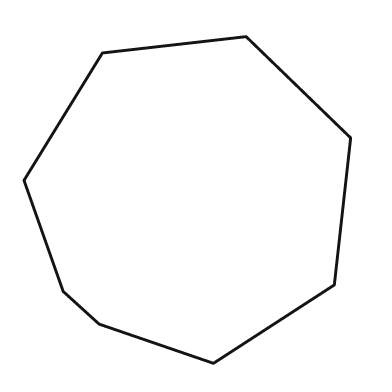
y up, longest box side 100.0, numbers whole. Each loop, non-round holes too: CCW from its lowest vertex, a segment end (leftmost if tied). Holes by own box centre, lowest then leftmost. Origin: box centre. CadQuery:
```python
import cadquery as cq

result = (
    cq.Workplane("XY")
    .moveTo(8.0, -50.0)
    .lineTo(45.0, -26.0)
    .lineTo(50.0, 19.0)
    .lineTo(18.0, 50.0)
    .lineTo(-26.0, 45.0)
    .lineTo(-50.0, 6.0)
    .lineTo(-38.0, -28.0)
    .lineTo(-27.0, -38.0)
    .close()
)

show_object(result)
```